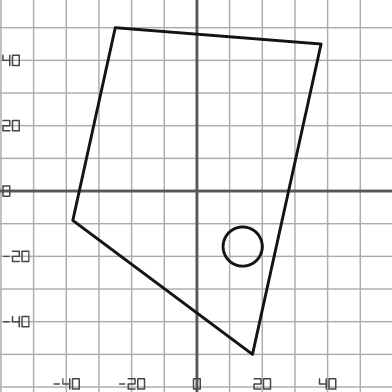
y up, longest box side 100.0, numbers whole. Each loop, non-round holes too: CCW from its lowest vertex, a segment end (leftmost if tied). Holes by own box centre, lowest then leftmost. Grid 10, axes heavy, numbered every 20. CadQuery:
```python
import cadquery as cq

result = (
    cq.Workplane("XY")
    .moveTo(17.0, -50.0)
    .lineTo(38.0, 45.0)
    .lineTo(-25.0, 50.0)
    .lineTo(-38.0, -9.0)
    .close()
    .moveTo(14.0, -17.0)
    .circle(6.0)
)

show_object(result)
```